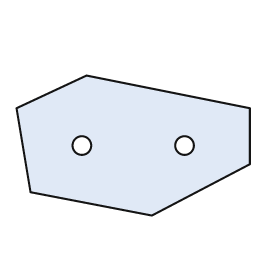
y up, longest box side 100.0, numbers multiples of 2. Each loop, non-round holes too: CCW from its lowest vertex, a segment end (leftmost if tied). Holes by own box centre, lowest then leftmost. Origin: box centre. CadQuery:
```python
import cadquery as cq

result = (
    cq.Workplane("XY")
    .moveTo(8.0, -30.0)
    .lineTo(50.0, -8.0)
    .lineTo(50.0, 16.0)
    .lineTo(-20.0, 30.0)
    .lineTo(-50.0, 16.0)
    .lineTo(-44.0, -20.0)
    .close()
    .moveTo(-22.0, 0.0)
    .circle(4.0)
    .moveTo(22.0, 0.0)
    .circle(4.0)
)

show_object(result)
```